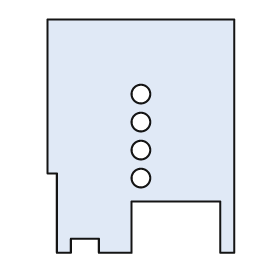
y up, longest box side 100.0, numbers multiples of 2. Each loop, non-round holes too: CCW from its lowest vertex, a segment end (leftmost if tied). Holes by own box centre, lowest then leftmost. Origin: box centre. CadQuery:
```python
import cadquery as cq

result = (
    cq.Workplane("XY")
    .moveTo(-36.0, -50.0)
    .lineTo(-30.0, -50.0)
    .lineTo(-30.0, -44.0)
    .lineTo(-18.0, -44.0)
    .lineTo(-18.0, -50.0)
    .lineTo(-4.0, -50.0)
    .lineTo(-4.0, -28.0)
    .lineTo(34.0, -28.0)
    .lineTo(34.0, -50.0)
    .lineTo(40.0, -50.0)
    .lineTo(40.0, 50.0)
    .lineTo(-40.0, 50.0)
    .lineTo(-40.0, -16.0)
    .lineTo(-36.0, -16.0)
    .close()
    .moveTo(0.0, -18.0)
    .circle(4.0)
    .moveTo(0.0, -6.0)
    .circle(4.0)
    .moveTo(0.0, 6.0)
    .circle(4.0)
    .moveTo(0.0, 18.0)
    .circle(4.0)
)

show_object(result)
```